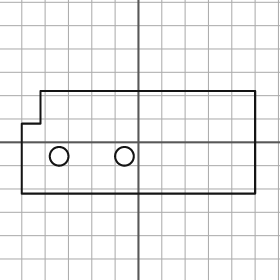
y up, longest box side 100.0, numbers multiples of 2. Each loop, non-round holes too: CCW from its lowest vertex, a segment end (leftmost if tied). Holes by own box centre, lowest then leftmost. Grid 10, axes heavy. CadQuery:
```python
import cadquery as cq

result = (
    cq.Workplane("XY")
    .moveTo(-50.0, -22.0)
    .lineTo(50.0, -22.0)
    .lineTo(50.0, 22.0)
    .lineTo(-42.0, 22.0)
    .lineTo(-42.0, 8.0)
    .lineTo(-50.0, 8.0)
    .close()
    .moveTo(-34.0, -6.0)
    .circle(4.0)
    .moveTo(-6.0, -6.0)
    .circle(4.0)
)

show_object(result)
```